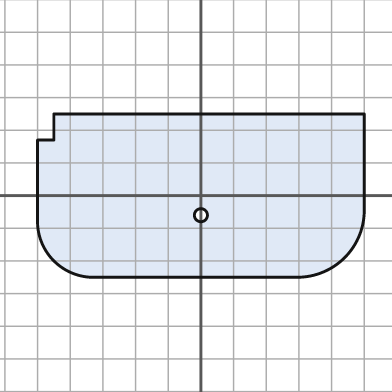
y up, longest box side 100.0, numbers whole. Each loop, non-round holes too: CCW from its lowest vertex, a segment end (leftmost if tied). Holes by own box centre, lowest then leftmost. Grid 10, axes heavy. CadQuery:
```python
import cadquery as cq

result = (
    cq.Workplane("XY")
    .moveTo(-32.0, -25.0)
    .lineTo(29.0, -25.0)
    .threePointArc((44.0, -19.0), (50.0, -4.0))
    .lineTo(50.0, 25.0)
    .lineTo(-45.0, 25.0)
    .lineTo(-45.0, 17.0)
    .lineTo(-50.0, 17.0)
    .lineTo(-50.0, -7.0)
    .threePointArc((-45.0, -20.0), (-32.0, -25.0))
    .close()
    .moveTo(0.0, -6.0)
    .circle(2.0)
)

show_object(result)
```